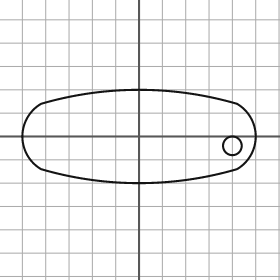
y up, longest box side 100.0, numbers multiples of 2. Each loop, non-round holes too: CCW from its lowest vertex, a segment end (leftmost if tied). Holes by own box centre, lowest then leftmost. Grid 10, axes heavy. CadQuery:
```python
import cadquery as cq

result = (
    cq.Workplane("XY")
    .moveTo(-42.0, -14.0)
    .threePointArc((0.0, -20.0), (42.0, -14.0))
    .threePointArc((50.0, 0.0), (42.0, 14.0))
    .threePointArc((0.0, 20.0), (-42.0, 14.0))
    .threePointArc((-50.0, 0.0), (-42.0, -14.0))
    .close()
    .moveTo(40.0, -4.0)
    .circle(4.0)
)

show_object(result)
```